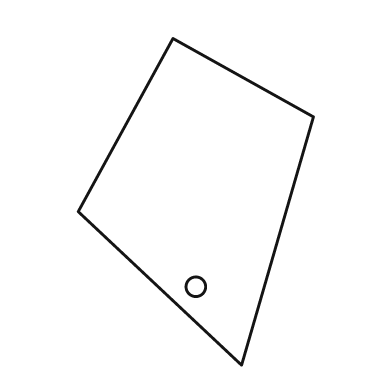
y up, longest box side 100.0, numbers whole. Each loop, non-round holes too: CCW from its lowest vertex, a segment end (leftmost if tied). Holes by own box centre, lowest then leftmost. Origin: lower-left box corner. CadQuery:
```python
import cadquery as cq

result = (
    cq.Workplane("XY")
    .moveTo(50.0, 0.0)
    .lineTo(72.0, 76.0)
    .lineTo(29.0, 100.0)
    .lineTo(0.0, 47.0)
    .close()
    .moveTo(36.0, 24.0)
    .circle(3.0)
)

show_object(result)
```